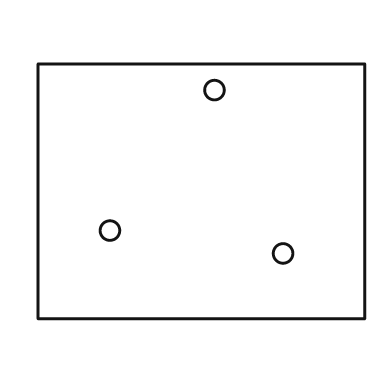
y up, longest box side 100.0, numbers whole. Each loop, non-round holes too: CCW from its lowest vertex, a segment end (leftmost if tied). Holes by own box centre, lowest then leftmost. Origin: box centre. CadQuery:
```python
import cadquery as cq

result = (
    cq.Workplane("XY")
    .moveTo(-50.0, -39.0)
    .lineTo(50.0, -39.0)
    .lineTo(50.0, 39.0)
    .lineTo(-50.0, 39.0)
    .close()
    .moveTo(25.0, -19.0)
    .circle(3.0)
    .moveTo(-28.0, -12.0)
    .circle(3.0)
    .moveTo(4.0, 31.0)
    .circle(3.0)
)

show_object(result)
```